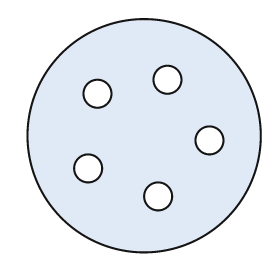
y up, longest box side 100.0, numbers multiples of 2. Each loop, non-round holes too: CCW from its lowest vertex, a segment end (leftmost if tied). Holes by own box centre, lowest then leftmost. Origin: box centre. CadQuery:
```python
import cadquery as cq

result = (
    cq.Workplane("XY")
    .moveTo(0.0, 0.0)
    .circle(50.0)
    .moveTo(6.0, -26.0)
    .circle(6.0)
    .moveTo(-24.0, -14.0)
    .circle(6.0)
    .moveTo(28.0, -2.0)
    .circle(6.0)
    .moveTo(-20.0, 18.0)
    .circle(6.0)
    .moveTo(10.0, 24.0)
    .circle(6.0)
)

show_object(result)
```